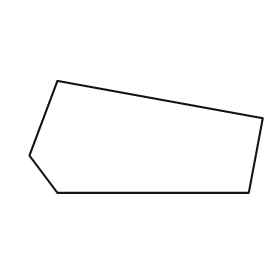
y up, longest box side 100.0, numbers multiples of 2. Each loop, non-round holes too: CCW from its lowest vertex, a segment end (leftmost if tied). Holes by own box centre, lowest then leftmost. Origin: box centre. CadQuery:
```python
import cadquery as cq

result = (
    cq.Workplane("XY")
    .moveTo(-38.0, -24.0)
    .lineTo(44.0, -24.0)
    .lineTo(50.0, 8.0)
    .lineTo(-38.0, 24.0)
    .lineTo(-50.0, -8.0)
    .close()
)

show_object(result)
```